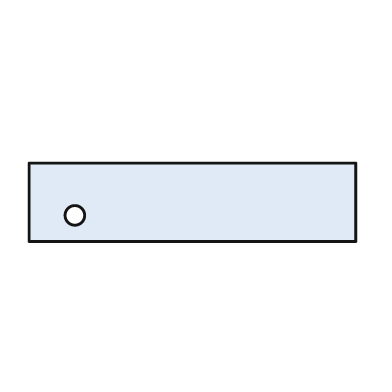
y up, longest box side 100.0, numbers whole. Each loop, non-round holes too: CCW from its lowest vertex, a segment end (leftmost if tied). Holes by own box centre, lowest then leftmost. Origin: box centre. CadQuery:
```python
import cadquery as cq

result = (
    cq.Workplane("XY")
    .moveTo(-50.0, -12.0)
    .lineTo(50.0, -12.0)
    .lineTo(50.0, 12.0)
    .lineTo(-50.0, 12.0)
    .close()
    .moveTo(-36.0, -4.0)
    .circle(3.0)
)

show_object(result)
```